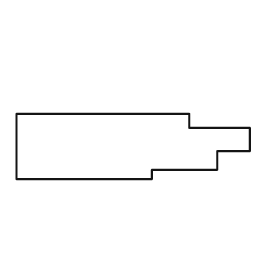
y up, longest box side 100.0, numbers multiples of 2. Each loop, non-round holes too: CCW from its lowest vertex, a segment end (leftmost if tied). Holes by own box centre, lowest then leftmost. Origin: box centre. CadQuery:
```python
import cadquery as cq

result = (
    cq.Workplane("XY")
    .moveTo(-50.0, -14.0)
    .lineTo(8.0, -14.0)
    .lineTo(8.0, -10.0)
    .lineTo(36.0, -10.0)
    .lineTo(36.0, -2.0)
    .lineTo(50.0, -2.0)
    .lineTo(50.0, 8.0)
    .lineTo(24.0, 8.0)
    .lineTo(24.0, 14.0)
    .lineTo(-50.0, 14.0)
    .close()
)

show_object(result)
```